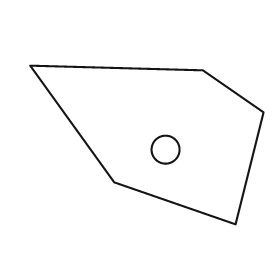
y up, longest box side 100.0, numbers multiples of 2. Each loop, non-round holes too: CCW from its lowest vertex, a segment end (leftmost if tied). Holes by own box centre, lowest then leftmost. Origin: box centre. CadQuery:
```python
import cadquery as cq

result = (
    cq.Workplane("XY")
    .moveTo(38.0, -34.0)
    .lineTo(50.0, 14.0)
    .lineTo(24.0, 32.0)
    .lineTo(-50.0, 34.0)
    .lineTo(-14.0, -16.0)
    .close()
    .moveTo(8.0, -2.0)
    .circle(6.0)
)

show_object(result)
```